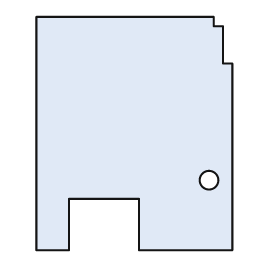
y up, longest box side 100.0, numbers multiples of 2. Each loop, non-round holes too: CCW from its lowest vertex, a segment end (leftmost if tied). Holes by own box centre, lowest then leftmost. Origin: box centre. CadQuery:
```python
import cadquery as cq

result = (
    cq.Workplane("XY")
    .moveTo(-42.0, -50.0)
    .lineTo(-28.0, -50.0)
    .lineTo(-28.0, -28.0)
    .lineTo(2.0, -28.0)
    .lineTo(2.0, -50.0)
    .lineTo(42.0, -50.0)
    .lineTo(42.0, 30.0)
    .lineTo(38.0, 30.0)
    .lineTo(38.0, 46.0)
    .lineTo(34.0, 46.0)
    .lineTo(34.0, 50.0)
    .lineTo(-42.0, 50.0)
    .close()
    .moveTo(32.0, -20.0)
    .circle(4.0)
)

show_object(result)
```